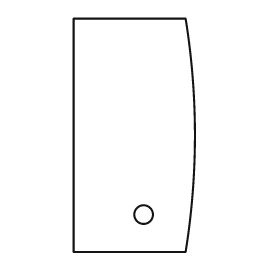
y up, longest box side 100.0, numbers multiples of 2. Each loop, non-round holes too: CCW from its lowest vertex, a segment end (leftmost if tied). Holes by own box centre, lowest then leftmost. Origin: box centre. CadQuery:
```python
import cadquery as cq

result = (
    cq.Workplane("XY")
    .moveTo(-26.0, -50.0)
    .lineTo(22.0, -50.0)
    .threePointArc((26.0, 0.0), (22.0, 50.0))
    .lineTo(-26.0, 50.0)
    .close()
    .moveTo(4.0, -34.0)
    .circle(4.0)
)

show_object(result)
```